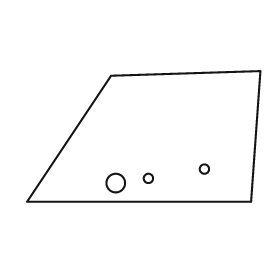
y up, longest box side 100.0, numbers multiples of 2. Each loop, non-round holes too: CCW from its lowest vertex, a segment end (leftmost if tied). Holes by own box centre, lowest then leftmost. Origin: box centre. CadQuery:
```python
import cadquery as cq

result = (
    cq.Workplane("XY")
    .moveTo(-50.0, -28.0)
    .lineTo(46.0, -28.0)
    .lineTo(50.0, 28.0)
    .lineTo(-14.0, 26.0)
    .close()
    .moveTo(-12.0, -20.0)
    .circle(4.0)
    .moveTo(2.0, -18.0)
    .circle(2.0)
    .moveTo(26.0, -14.0)
    .circle(2.0)
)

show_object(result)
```